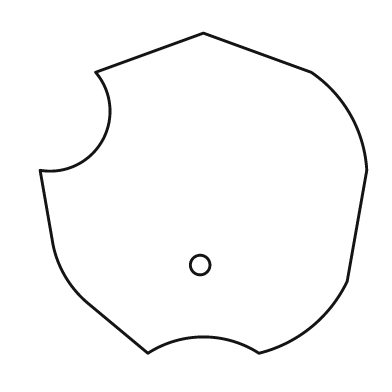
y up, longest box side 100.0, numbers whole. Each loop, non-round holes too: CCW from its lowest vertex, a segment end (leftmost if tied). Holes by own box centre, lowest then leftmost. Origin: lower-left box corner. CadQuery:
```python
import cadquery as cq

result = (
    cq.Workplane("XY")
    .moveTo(33.0, 0.0)
    .threePointArc((50.0, 5.0), (67.0, 0.0))
    .threePointArc((83.0, 8.0), (94.0, 22.0))
    .lineTo(100.0, 56.0)
    .threePointArc((95.0, 73.0), (83.0, 86.0))
    .lineTo(50.0, 98.0)
    .lineTo(17.0, 86.0)
    .threePointArc((19.0, 65.0), (0.0, 56.0))
    .lineTo(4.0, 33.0)
    .threePointArc((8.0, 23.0), (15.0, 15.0))
    .close()
    .moveTo(49.0, 27.0)
    .circle(3.0)
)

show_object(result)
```